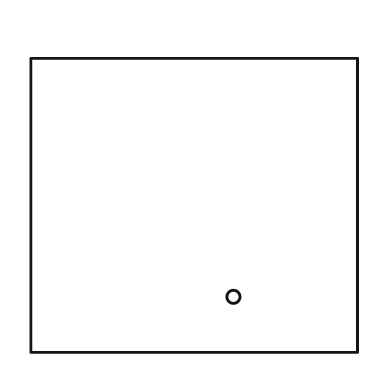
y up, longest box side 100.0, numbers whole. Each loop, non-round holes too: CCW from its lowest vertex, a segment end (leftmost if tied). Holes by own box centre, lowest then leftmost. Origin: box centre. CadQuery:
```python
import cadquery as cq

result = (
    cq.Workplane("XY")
    .moveTo(-50.0, -45.0)
    .lineTo(50.0, -45.0)
    .lineTo(50.0, 45.0)
    .lineTo(-50.0, 45.0)
    .close()
    .moveTo(12.0, -28.0)
    .circle(2.0)
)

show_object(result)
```